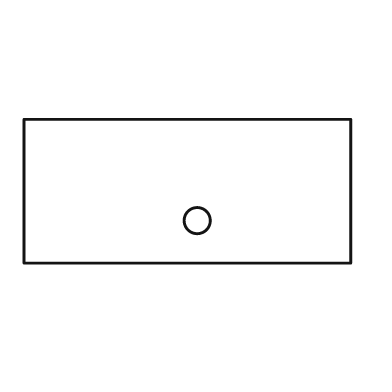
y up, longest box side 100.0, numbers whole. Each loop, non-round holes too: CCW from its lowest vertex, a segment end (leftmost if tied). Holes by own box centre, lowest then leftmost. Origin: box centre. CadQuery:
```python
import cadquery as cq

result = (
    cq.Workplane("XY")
    .moveTo(-50.0, -22.0)
    .lineTo(50.0, -22.0)
    .lineTo(50.0, 22.0)
    .lineTo(-50.0, 22.0)
    .close()
    .moveTo(3.0, -9.0)
    .circle(4.0)
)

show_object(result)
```